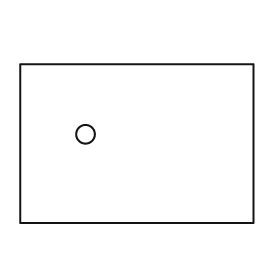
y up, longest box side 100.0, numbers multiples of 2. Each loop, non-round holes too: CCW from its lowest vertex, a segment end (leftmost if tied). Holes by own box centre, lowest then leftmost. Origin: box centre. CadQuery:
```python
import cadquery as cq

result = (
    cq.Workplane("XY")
    .moveTo(-50.0, -34.0)
    .lineTo(50.0, -34.0)
    .lineTo(50.0, 34.0)
    .lineTo(-50.0, 34.0)
    .close()
    .moveTo(-22.0, 4.0)
    .circle(4.0)
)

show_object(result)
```